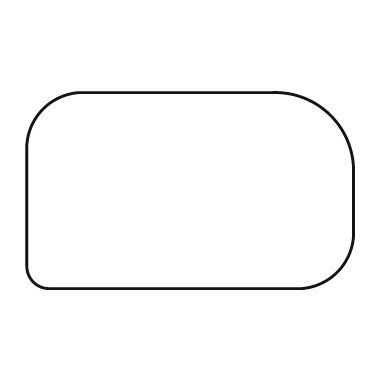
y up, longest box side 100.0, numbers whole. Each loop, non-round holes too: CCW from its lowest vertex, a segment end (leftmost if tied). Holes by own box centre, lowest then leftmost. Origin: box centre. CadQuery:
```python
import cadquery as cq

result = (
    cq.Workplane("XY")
    .moveTo(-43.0, -30.0)
    .lineTo(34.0, -30.0)
    .threePointArc((45.0, -25.0), (50.0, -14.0))
    .lineTo(50.0, 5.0)
    .threePointArc((43.0, 23.0), (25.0, 30.0))
    .lineTo(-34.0, 30.0)
    .threePointArc((-45.0, 25.0), (-50.0, 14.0))
    .lineTo(-50.0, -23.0)
    .threePointArc((-48.0, -28.0), (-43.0, -30.0))
    .close()
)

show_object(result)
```